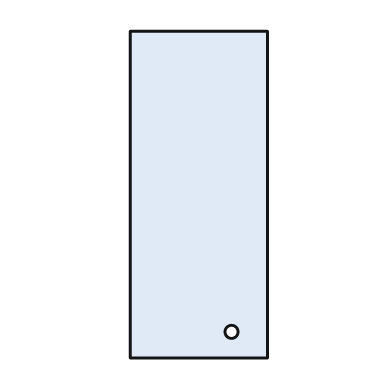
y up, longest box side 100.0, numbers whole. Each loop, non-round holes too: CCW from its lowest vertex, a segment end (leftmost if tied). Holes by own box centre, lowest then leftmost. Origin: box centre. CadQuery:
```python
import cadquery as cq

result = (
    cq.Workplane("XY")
    .moveTo(-21.0, -50.0)
    .lineTo(21.0, -50.0)
    .lineTo(21.0, 50.0)
    .lineTo(-21.0, 50.0)
    .close()
    .moveTo(10.0, -42.0)
    .circle(2.0)
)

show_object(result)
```